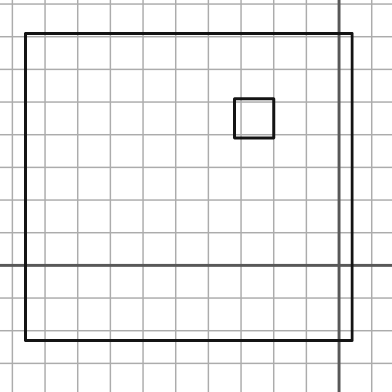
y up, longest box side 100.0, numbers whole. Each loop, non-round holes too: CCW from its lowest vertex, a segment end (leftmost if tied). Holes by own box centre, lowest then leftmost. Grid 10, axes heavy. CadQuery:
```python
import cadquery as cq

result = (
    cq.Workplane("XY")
    .moveTo(-96.0, -23.0)
    .lineTo(4.0, -23.0)
    .lineTo(4.0, 71.0)
    .lineTo(-96.0, 71.0)
    .close()
    .moveTo(-32.0, 39.0)
    .lineTo(-20.0, 39.0)
    .lineTo(-20.0, 51.0)
    .lineTo(-32.0, 51.0)
    .close()
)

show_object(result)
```